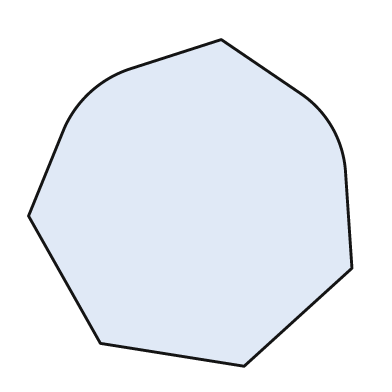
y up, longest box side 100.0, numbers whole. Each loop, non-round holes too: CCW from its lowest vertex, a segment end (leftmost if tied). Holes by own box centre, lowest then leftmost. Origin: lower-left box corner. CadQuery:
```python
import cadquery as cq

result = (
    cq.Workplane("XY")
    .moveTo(66.0, 0.0)
    .lineTo(99.0, 30.0)
    .lineTo(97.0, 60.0)
    .threePointArc((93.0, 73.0), (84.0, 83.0))
    .lineTo(59.0, 100.0)
    .lineTo(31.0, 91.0)
    .threePointArc((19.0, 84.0), (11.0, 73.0))
    .lineTo(0.0, 46.0)
    .lineTo(22.0, 7.0)
    .close()
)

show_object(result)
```